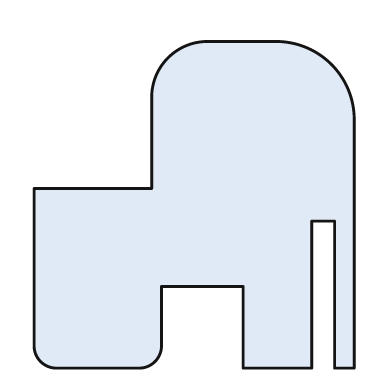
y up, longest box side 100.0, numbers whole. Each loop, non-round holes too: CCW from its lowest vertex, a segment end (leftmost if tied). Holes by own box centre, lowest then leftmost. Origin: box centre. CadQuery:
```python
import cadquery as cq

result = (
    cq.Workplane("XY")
    .moveTo(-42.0, -50.0)
    .lineTo(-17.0, -50.0)
    .threePointArc((-12.0, -48.0), (-10.0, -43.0))
    .lineTo(-10.0, -25.0)
    .lineTo(15.0, -25.0)
    .lineTo(15.0, -50.0)
    .lineTo(36.0, -50.0)
    .lineTo(36.0, -5.0)
    .lineTo(43.0, -5.0)
    .lineTo(43.0, -50.0)
    .lineTo(49.0, -50.0)
    .lineTo(49.0, 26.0)
    .threePointArc((42.0, 43.0), (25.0, 50.0))
    .lineTo(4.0, 50.0)
    .threePointArc((-8.0, 45.0), (-13.0, 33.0))
    .lineTo(-13.0, 5.0)
    .lineTo(-49.0, 5.0)
    .lineTo(-49.0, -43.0)
    .threePointArc((-47.0, -48.0), (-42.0, -50.0))
    .close()
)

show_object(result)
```